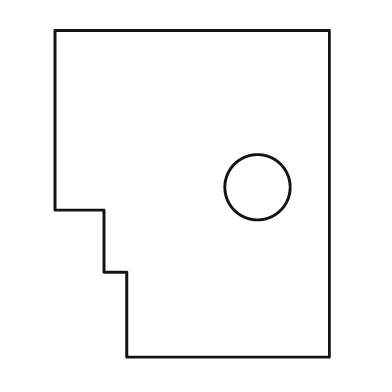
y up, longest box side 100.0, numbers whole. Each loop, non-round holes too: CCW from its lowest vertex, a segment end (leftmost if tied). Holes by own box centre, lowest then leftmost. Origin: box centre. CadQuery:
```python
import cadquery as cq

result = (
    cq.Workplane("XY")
    .moveTo(-20.0, -50.0)
    .lineTo(42.0, -50.0)
    .lineTo(42.0, 50.0)
    .lineTo(-42.0, 50.0)
    .lineTo(-42.0, -5.0)
    .lineTo(-27.0, -5.0)
    .lineTo(-27.0, -24.0)
    .lineTo(-20.0, -24.0)
    .close()
    .moveTo(20.0, 2.0)
    .circle(10.0)
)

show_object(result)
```